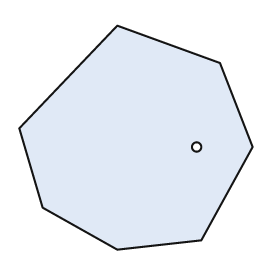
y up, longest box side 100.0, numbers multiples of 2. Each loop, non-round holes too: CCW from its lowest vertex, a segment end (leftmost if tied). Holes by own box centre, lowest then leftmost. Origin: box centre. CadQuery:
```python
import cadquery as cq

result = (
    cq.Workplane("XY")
    .moveTo(-8.0, -48.0)
    .lineTo(28.0, -44.0)
    .lineTo(50.0, -4.0)
    .lineTo(36.0, 32.0)
    .lineTo(-8.0, 48.0)
    .lineTo(-50.0, 4.0)
    .lineTo(-40.0, -30.0)
    .close()
    .moveTo(26.0, -4.0)
    .circle(2.0)
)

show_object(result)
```